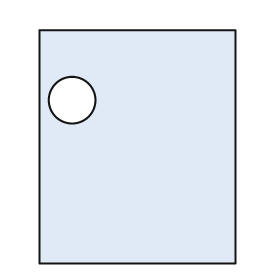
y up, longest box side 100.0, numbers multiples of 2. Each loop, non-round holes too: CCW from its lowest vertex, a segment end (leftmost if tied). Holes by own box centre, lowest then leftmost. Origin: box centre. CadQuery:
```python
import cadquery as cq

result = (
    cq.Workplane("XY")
    .moveTo(-42.0, -50.0)
    .lineTo(42.0, -50.0)
    .lineTo(42.0, 50.0)
    .lineTo(-42.0, 50.0)
    .close()
    .moveTo(-28.0, 20.0)
    .circle(10.0)
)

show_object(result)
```